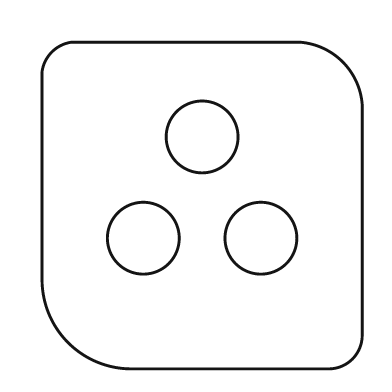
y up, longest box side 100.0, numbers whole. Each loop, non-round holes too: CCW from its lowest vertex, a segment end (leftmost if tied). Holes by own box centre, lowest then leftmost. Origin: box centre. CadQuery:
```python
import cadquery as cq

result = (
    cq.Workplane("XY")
    .moveTo(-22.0, -50.0)
    .lineTo(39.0, -50.0)
    .threePointArc((46.0, -47.0), (49.0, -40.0))
    .lineTo(49.0, 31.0)
    .threePointArc((43.0, 44.0), (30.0, 50.0))
    .lineTo(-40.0, 50.0)
    .threePointArc((-46.0, 47.0), (-49.0, 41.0))
    .lineTo(-49.0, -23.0)
    .threePointArc((-41.0, -42.0), (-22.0, -50.0))
    .close()
    .moveTo(-18.0, -10.0)
    .circle(11.0)
    .moveTo(18.0, -10.0)
    .circle(11.0)
    .moveTo(0.0, 21.0)
    .circle(11.0)
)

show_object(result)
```